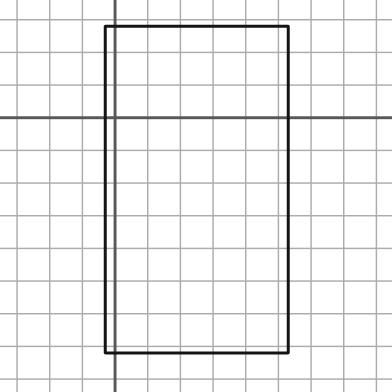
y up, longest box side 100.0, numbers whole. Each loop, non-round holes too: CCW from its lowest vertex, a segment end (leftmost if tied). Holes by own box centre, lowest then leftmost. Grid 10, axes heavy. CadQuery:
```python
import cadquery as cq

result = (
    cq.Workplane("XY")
    .moveTo(-3.0, -72.0)
    .lineTo(53.0, -72.0)
    .lineTo(53.0, 28.0)
    .lineTo(-3.0, 28.0)
    .close()
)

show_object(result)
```